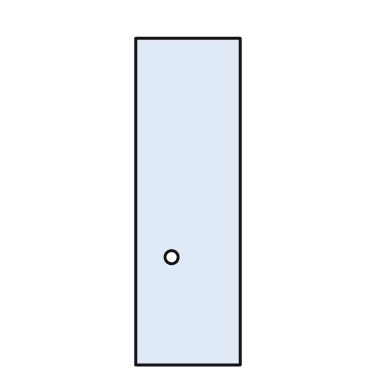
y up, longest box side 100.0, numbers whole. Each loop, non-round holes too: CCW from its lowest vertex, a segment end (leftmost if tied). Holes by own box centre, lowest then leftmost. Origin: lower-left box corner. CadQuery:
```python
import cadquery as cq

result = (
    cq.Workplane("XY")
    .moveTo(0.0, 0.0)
    .lineTo(32.0, 0.0)
    .lineTo(32.0, 100.0)
    .lineTo(0.0, 100.0)
    .close()
    .moveTo(11.0, 33.0)
    .circle(2.0)
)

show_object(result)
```